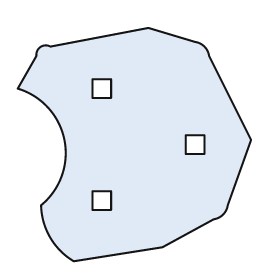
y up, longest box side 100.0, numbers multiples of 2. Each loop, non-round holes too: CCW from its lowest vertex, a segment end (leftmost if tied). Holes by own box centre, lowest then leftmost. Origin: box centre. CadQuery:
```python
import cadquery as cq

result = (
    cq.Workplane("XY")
    .moveTo(-26.0, -50.0)
    .lineTo(12.0, -44.0)
    .lineTo(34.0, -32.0)
    .threePointArc((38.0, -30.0), (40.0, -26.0))
    .lineTo(50.0, 2.0)
    .lineTo(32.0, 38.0)
    .threePointArc((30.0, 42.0), (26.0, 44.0))
    .lineTo(6.0, 50.0)
    .lineTo(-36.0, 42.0)
    .threePointArc((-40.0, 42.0), (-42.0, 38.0))
    .lineTo(-50.0, 24.0)
    .threePointArc((-30.0, 2.0), (-40.0, -26.0))
    .threePointArc((-36.0, -40.0), (-26.0, -50.0))
    .close()
    .moveTo(-18.0, -28.0)
    .lineTo(-10.0, -28.0)
    .lineTo(-10.0, -20.0)
    .lineTo(-18.0, -20.0)
    .close()
    .moveTo(22.0, -4.0)
    .lineTo(30.0, -4.0)
    .lineTo(30.0, 4.0)
    .lineTo(22.0, 4.0)
    .close()
    .moveTo(-18.0, 20.0)
    .lineTo(-10.0, 20.0)
    .lineTo(-10.0, 28.0)
    .lineTo(-18.0, 28.0)
    .close()
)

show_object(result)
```